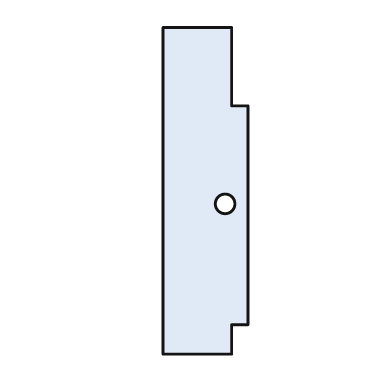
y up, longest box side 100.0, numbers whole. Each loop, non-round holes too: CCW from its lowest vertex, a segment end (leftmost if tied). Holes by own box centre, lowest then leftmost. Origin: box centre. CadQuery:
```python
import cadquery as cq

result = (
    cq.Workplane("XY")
    .moveTo(-13.0, -50.0)
    .lineTo(8.0, -50.0)
    .lineTo(8.0, -41.0)
    .lineTo(13.0, -41.0)
    .lineTo(13.0, 26.0)
    .lineTo(8.0, 26.0)
    .lineTo(8.0, 50.0)
    .lineTo(-13.0, 50.0)
    .close()
    .moveTo(6.0, -4.0)
    .circle(3.0)
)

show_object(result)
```